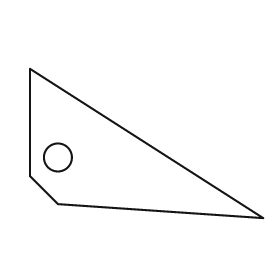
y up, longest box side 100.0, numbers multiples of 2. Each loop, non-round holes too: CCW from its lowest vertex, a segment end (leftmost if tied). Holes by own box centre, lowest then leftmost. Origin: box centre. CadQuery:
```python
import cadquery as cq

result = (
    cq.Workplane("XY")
    .moveTo(50.0, -32.0)
    .lineTo(-50.0, 32.0)
    .lineTo(-50.0, -14.0)
    .lineTo(-38.0, -26.0)
    .close()
    .moveTo(-38.0, -6.0)
    .circle(6.0)
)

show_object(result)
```